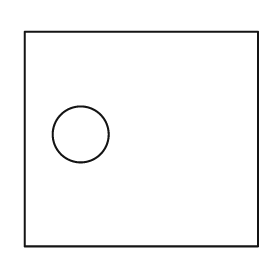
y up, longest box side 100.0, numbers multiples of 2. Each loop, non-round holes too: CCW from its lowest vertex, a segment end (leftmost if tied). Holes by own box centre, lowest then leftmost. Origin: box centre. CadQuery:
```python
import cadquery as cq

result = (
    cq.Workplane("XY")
    .moveTo(-50.0, -46.0)
    .lineTo(50.0, -46.0)
    .lineTo(50.0, 46.0)
    .lineTo(-50.0, 46.0)
    .close()
    .moveTo(-26.0, 2.0)
    .circle(12.0)
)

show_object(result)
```